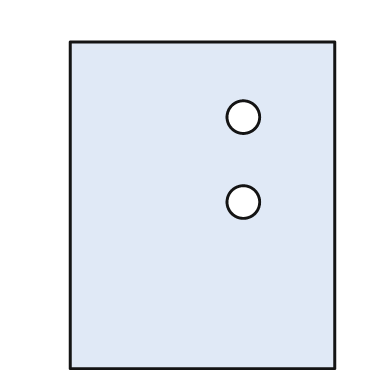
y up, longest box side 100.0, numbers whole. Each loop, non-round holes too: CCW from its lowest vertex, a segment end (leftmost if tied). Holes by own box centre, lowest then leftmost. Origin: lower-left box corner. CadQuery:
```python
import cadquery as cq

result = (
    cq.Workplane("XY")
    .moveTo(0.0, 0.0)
    .lineTo(81.0, 0.0)
    .lineTo(81.0, 100.0)
    .lineTo(0.0, 100.0)
    .close()
    .moveTo(53.0, 51.0)
    .circle(5.0)
    .moveTo(53.0, 77.0)
    .circle(5.0)
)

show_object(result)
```